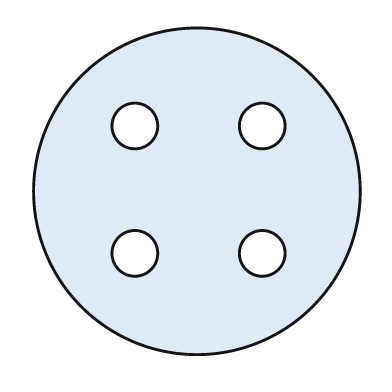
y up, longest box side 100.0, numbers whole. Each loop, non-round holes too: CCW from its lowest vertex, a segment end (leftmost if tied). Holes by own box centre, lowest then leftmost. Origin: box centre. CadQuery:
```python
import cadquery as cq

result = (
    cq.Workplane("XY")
    .moveTo(0.0, 0.0)
    .circle(50.0)
    .moveTo(-19.0, -19.0)
    .circle(7.0)
    .moveTo(20.0, -19.0)
    .circle(7.0)
    .moveTo(-19.0, 20.0)
    .circle(7.0)
    .moveTo(20.0, 20.0)
    .circle(7.0)
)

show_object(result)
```